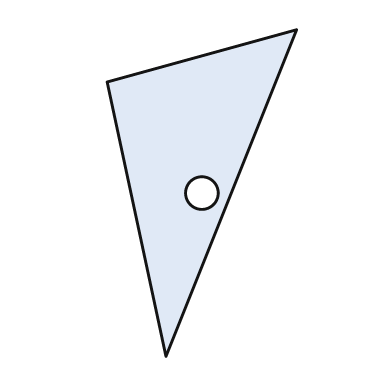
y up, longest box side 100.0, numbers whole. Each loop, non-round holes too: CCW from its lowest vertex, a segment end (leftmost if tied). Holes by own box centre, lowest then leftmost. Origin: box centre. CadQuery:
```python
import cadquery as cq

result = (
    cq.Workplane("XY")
    .moveTo(-11.0, -50.0)
    .lineTo(29.0, 50.0)
    .lineTo(-29.0, 34.0)
    .close()
    .moveTo(0.0, 0.0)
    .circle(5.0)
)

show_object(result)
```